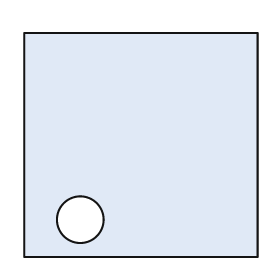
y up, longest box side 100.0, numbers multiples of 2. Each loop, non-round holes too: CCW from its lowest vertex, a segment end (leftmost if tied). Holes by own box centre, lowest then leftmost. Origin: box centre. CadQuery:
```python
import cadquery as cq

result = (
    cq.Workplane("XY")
    .moveTo(-50.0, -48.0)
    .lineTo(50.0, -48.0)
    .lineTo(50.0, 48.0)
    .lineTo(-50.0, 48.0)
    .close()
    .moveTo(-26.0, -32.0)
    .circle(10.0)
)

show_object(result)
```